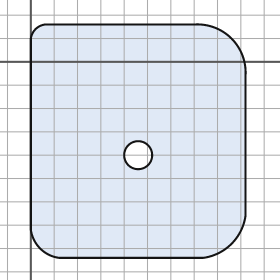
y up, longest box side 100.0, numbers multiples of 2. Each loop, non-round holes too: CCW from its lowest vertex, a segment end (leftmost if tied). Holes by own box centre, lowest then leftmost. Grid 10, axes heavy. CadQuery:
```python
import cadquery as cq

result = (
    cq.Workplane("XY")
    .moveTo(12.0, -84.0)
    .lineTo(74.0, -84.0)
    .threePointArc((86.0, -78.0), (92.0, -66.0))
    .lineTo(92.0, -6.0)
    .threePointArc((86.0, 10.0), (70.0, 16.0))
    .lineTo(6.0, 16.0)
    .threePointArc((2.0, 14.0), (0.0, 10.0))
    .lineTo(0.0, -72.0)
    .threePointArc((4.0, -80.0), (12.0, -84.0))
    .close()
    .moveTo(46.0, -40.0)
    .circle(6.0)
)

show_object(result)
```